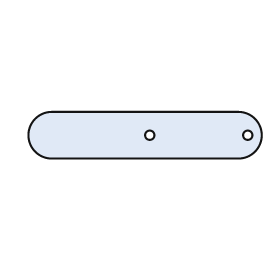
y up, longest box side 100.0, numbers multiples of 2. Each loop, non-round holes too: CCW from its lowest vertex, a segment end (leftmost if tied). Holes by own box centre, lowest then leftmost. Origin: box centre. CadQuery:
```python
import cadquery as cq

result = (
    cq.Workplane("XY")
    .moveTo(-40.0, -10.0)
    .lineTo(40.0, -10.0)
    .threePointArc((50.0, 0.0), (40.0, 10.0))
    .lineTo(-40.0, 10.0)
    .threePointArc((-50.0, 0.0), (-40.0, -10.0))
    .close()
    .moveTo(2.0, 0.0)
    .circle(2.0)
    .moveTo(44.0, 0.0)
    .circle(2.0)
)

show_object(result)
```